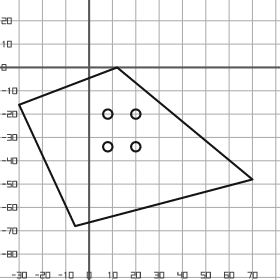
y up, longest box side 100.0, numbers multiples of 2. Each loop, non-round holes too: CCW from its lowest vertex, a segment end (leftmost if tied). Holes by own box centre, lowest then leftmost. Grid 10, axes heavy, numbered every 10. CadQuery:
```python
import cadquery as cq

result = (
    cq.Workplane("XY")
    .moveTo(-6.0, -68.0)
    .lineTo(70.0, -48.0)
    .lineTo(12.0, 0.0)
    .lineTo(-30.0, -16.0)
    .close()
    .moveTo(8.0, -34.0)
    .circle(2.0)
    .moveTo(20.0, -34.0)
    .circle(2.0)
    .moveTo(8.0, -20.0)
    .circle(2.0)
    .moveTo(20.0, -20.0)
    .circle(2.0)
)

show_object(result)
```